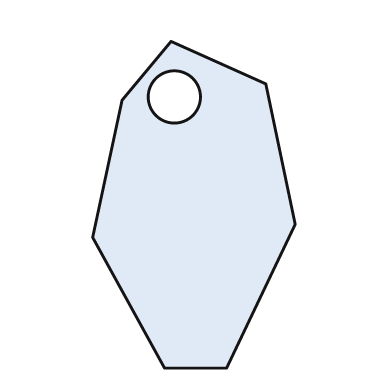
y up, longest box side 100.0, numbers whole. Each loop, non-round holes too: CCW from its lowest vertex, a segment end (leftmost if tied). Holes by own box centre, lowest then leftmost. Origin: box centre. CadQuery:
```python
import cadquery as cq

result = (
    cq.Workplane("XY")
    .moveTo(-9.0, -50.0)
    .lineTo(10.0, -50.0)
    .lineTo(31.0, -6.0)
    .lineTo(22.0, 37.0)
    .lineTo(-7.0, 50.0)
    .lineTo(-22.0, 32.0)
    .lineTo(-31.0, -10.0)
    .close()
    .moveTo(-6.0, 33.0)
    .circle(8.0)
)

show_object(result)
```